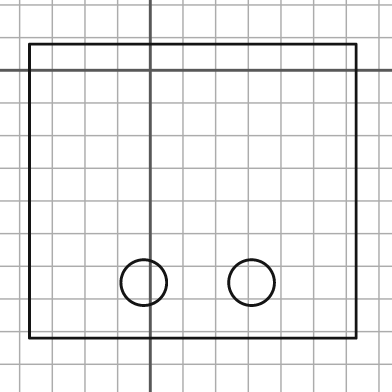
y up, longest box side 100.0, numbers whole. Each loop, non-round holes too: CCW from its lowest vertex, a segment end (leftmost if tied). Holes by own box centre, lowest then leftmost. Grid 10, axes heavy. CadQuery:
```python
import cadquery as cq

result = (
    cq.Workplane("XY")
    .moveTo(-37.0, -82.0)
    .lineTo(63.0, -82.0)
    .lineTo(63.0, 8.0)
    .lineTo(-37.0, 8.0)
    .close()
    .moveTo(-2.0, -65.0)
    .circle(7.0)
    .moveTo(31.0, -65.0)
    .circle(7.0)
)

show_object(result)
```